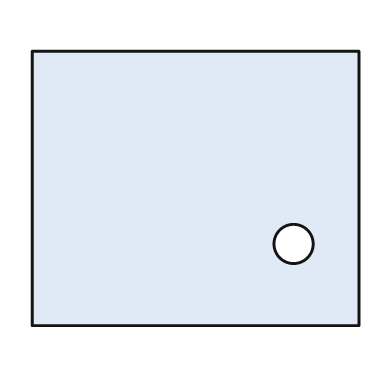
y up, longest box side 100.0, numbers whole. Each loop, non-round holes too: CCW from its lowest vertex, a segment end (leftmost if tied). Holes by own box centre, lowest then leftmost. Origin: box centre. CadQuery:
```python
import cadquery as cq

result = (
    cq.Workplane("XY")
    .moveTo(-50.0, -42.0)
    .lineTo(50.0, -42.0)
    .lineTo(50.0, 42.0)
    .lineTo(-50.0, 42.0)
    .close()
    .moveTo(30.0, -17.0)
    .circle(6.0)
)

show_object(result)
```